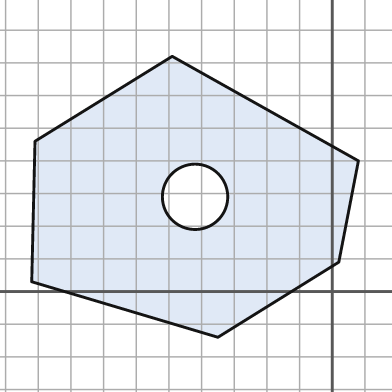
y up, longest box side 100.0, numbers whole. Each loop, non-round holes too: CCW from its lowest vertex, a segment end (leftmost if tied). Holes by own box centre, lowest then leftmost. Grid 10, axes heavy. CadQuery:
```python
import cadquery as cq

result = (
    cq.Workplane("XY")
    .moveTo(-35.0, -14.0)
    .lineTo(2.0, 9.0)
    .lineTo(8.0, 40.0)
    .lineTo(-49.0, 72.0)
    .lineTo(-91.0, 46.0)
    .lineTo(-92.0, 3.0)
    .close()
    .moveTo(-42.0, 29.0)
    .circle(10.0)
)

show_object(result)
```